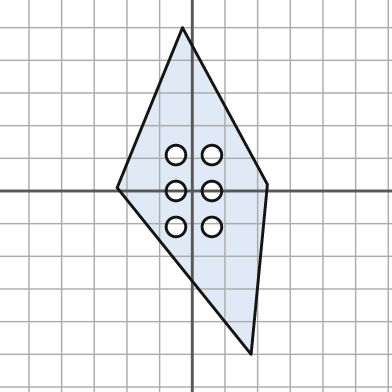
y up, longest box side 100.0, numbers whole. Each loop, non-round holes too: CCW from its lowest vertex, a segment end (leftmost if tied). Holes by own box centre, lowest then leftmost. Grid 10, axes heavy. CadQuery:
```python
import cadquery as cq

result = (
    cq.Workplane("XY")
    .moveTo(18.0, -50.0)
    .lineTo(23.0, 2.0)
    .lineTo(-3.0, 50.0)
    .lineTo(-23.0, 1.0)
    .close()
    .moveTo(-5.0, -11.0)
    .circle(3.0)
    .moveTo(6.0, -11.0)
    .circle(3.0)
    .moveTo(-5.0, 0.0)
    .circle(3.0)
    .moveTo(6.0, 0.0)
    .circle(3.0)
    .moveTo(-5.0, 11.0)
    .circle(3.0)
    .moveTo(6.0, 11.0)
    .circle(3.0)
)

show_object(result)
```